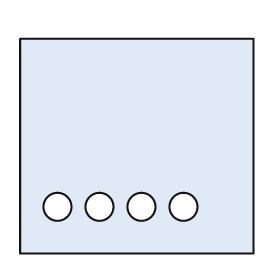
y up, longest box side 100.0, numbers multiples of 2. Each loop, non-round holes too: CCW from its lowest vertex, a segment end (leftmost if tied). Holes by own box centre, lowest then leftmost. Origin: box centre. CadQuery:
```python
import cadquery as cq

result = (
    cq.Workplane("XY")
    .moveTo(-50.0, -46.0)
    .lineTo(50.0, -46.0)
    .lineTo(50.0, 46.0)
    .lineTo(-50.0, 46.0)
    .close()
    .moveTo(-34.0, -26.0)
    .circle(6.0)
    .moveTo(-16.0, -26.0)
    .circle(6.0)
    .moveTo(2.0, -26.0)
    .circle(6.0)
    .moveTo(20.0, -26.0)
    .circle(6.0)
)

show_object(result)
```